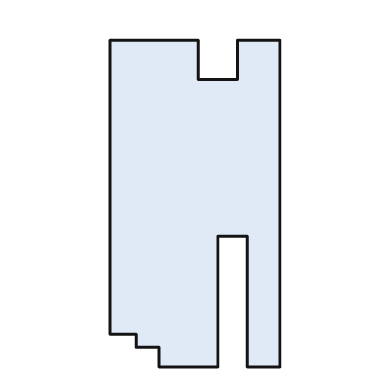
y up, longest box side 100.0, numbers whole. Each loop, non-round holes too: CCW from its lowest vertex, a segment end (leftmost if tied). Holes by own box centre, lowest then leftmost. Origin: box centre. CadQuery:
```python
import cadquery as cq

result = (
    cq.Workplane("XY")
    .moveTo(-11.0, -50.0)
    .lineTo(7.0, -50.0)
    .lineTo(7.0, -10.0)
    .lineTo(16.0, -10.0)
    .lineTo(16.0, -50.0)
    .lineTo(26.0, -50.0)
    .lineTo(26.0, 50.0)
    .lineTo(13.0, 50.0)
    .lineTo(13.0, 38.0)
    .lineTo(1.0, 38.0)
    .lineTo(1.0, 50.0)
    .lineTo(-26.0, 50.0)
    .lineTo(-26.0, -40.0)
    .lineTo(-18.0, -40.0)
    .lineTo(-18.0, -44.0)
    .lineTo(-11.0, -44.0)
    .close()
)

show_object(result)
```